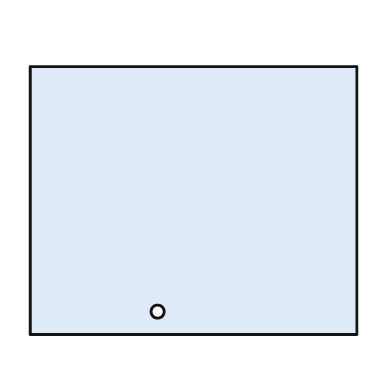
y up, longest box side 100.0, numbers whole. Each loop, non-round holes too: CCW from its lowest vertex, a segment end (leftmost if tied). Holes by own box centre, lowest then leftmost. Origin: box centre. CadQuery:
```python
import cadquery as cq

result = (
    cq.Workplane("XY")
    .moveTo(-50.0, -41.0)
    .lineTo(50.0, -41.0)
    .lineTo(50.0, 41.0)
    .lineTo(-50.0, 41.0)
    .close()
    .moveTo(-11.0, -34.0)
    .circle(2.0)
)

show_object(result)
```